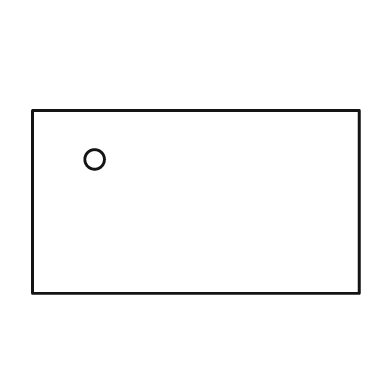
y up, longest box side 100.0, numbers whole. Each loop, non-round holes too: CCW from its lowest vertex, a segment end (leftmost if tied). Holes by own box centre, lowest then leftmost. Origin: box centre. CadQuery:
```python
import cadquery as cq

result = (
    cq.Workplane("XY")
    .moveTo(-50.0, -28.0)
    .lineTo(50.0, -28.0)
    .lineTo(50.0, 28.0)
    .lineTo(-50.0, 28.0)
    .close()
    .moveTo(-31.0, 13.0)
    .circle(3.0)
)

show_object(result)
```